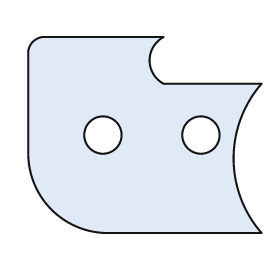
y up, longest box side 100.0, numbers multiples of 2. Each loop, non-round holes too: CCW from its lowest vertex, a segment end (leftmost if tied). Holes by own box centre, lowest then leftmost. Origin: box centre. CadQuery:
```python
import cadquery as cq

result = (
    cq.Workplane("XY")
    .moveTo(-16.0, -42.0)
    .lineTo(50.0, -42.0)
    .threePointArc((38.0, -10.0), (50.0, 22.0))
    .lineTo(8.0, 22.0)
    .threePointArc((2.0, 32.0), (8.0, 42.0))
    .lineTo(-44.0, 42.0)
    .threePointArc((-48.0, 40.0), (-50.0, 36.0))
    .lineTo(-50.0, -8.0)
    .threePointArc((-40.0, -32.0), (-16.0, -42.0))
    .close()
    .moveTo(-18.0, 0.0)
    .circle(8.0)
    .moveTo(24.0, 0.0)
    .circle(8.0)
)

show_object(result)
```